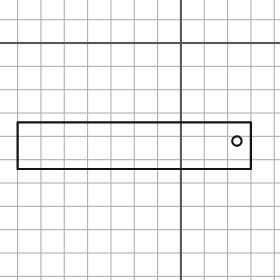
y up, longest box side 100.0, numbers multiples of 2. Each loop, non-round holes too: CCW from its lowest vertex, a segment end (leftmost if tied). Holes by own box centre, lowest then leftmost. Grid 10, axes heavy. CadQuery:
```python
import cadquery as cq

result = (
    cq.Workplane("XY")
    .moveTo(-70.0, -54.0)
    .lineTo(30.0, -54.0)
    .lineTo(30.0, -34.0)
    .lineTo(-70.0, -34.0)
    .close()
    .moveTo(24.0, -42.0)
    .circle(2.0)
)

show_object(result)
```